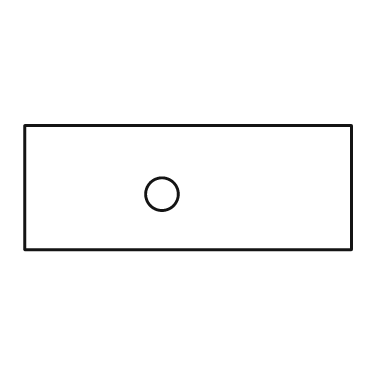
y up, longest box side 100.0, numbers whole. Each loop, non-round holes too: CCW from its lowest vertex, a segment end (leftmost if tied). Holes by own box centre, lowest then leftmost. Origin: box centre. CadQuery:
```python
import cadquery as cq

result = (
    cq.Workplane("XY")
    .moveTo(-50.0, -19.0)
    .lineTo(50.0, -19.0)
    .lineTo(50.0, 19.0)
    .lineTo(-50.0, 19.0)
    .close()
    .moveTo(-8.0, -2.0)
    .circle(5.0)
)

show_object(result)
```